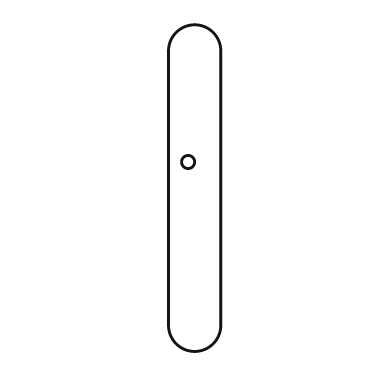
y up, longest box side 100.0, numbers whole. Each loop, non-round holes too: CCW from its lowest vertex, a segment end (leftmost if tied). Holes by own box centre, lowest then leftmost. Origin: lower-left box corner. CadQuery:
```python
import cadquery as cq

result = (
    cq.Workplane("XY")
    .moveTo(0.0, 8.0)
    .threePointArc((8.0, 0.0), (16.0, 8.0))
    .lineTo(16.0, 92.0)
    .threePointArc((8.0, 100.0), (0.0, 92.0))
    .close()
    .moveTo(6.0, 58.0)
    .circle(2.0)
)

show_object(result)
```